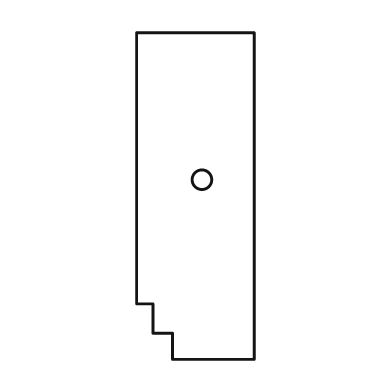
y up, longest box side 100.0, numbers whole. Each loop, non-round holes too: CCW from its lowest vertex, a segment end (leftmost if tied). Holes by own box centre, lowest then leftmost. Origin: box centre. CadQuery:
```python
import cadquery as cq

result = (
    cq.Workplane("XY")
    .moveTo(-7.0, -50.0)
    .lineTo(18.0, -50.0)
    .lineTo(18.0, 50.0)
    .lineTo(-18.0, 50.0)
    .lineTo(-18.0, -33.0)
    .lineTo(-13.0, -33.0)
    .lineTo(-13.0, -42.0)
    .lineTo(-7.0, -42.0)
    .close()
    .moveTo(2.0, 5.0)
    .circle(3.0)
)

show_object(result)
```